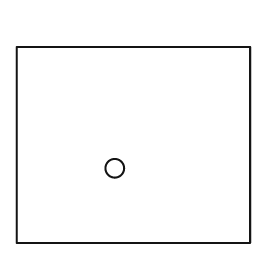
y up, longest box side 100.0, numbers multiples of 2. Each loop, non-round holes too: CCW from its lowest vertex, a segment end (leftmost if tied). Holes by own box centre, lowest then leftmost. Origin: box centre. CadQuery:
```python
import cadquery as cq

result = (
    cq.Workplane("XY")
    .moveTo(-50.0, -42.0)
    .lineTo(50.0, -42.0)
    .lineTo(50.0, 42.0)
    .lineTo(-50.0, 42.0)
    .close()
    .moveTo(-8.0, -10.0)
    .circle(4.0)
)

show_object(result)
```